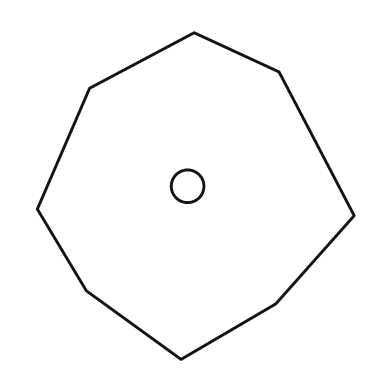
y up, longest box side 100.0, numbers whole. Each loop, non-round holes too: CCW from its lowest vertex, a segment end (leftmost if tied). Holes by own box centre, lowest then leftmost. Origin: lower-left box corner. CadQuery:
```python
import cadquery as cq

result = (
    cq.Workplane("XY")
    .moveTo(44.0, 0.0)
    .lineTo(73.0, 17.0)
    .lineTo(97.0, 44.0)
    .lineTo(74.0, 88.0)
    .lineTo(48.0, 100.0)
    .lineTo(16.0, 83.0)
    .lineTo(0.0, 46.0)
    .lineTo(15.0, 21.0)
    .close()
    .moveTo(46.0, 53.0)
    .circle(5.0)
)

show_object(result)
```